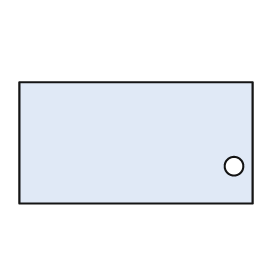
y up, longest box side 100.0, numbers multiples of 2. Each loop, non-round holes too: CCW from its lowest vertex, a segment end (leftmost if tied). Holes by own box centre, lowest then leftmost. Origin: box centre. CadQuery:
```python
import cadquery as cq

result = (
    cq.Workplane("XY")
    .moveTo(-50.0, -26.0)
    .lineTo(50.0, -26.0)
    .lineTo(50.0, 26.0)
    .lineTo(-50.0, 26.0)
    .close()
    .moveTo(42.0, -10.0)
    .circle(4.0)
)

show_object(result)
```